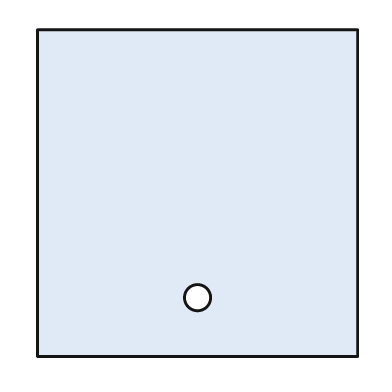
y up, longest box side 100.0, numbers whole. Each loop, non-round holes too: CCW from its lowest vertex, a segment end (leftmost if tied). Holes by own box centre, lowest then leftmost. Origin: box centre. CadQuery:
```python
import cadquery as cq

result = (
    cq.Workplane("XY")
    .moveTo(-49.0, -50.0)
    .lineTo(49.0, -50.0)
    .lineTo(49.0, 50.0)
    .lineTo(-49.0, 50.0)
    .close()
    .moveTo(0.0, -32.0)
    .circle(4.0)
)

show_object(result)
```